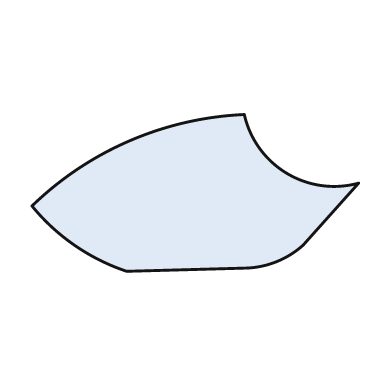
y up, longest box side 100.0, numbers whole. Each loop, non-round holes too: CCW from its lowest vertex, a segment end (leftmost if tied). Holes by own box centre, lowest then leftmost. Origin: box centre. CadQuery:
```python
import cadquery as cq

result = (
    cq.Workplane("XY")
    .moveTo(-21.0, -24.0)
    .lineTo(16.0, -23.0)
    .threePointArc((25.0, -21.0), (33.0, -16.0))
    .lineTo(50.0, 3.0)
    .threePointArc((28.0, 6.0), (15.0, 24.0))
    .threePointArc((-20.0, 16.0), (-50.0, -4.0))
    .threePointArc((-37.0, -16.0), (-21.0, -24.0))
    .close()
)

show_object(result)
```